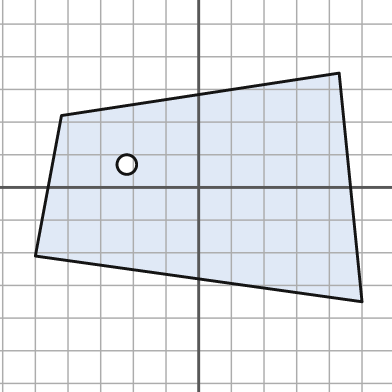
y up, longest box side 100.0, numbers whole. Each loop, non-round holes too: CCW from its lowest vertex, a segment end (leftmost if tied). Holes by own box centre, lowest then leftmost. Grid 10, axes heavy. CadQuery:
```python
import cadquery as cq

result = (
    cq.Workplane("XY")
    .moveTo(50.0, -35.0)
    .lineTo(43.0, 35.0)
    .lineTo(-42.0, 22.0)
    .lineTo(-50.0, -21.0)
    .close()
    .moveTo(-22.0, 7.0)
    .circle(3.0)
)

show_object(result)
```